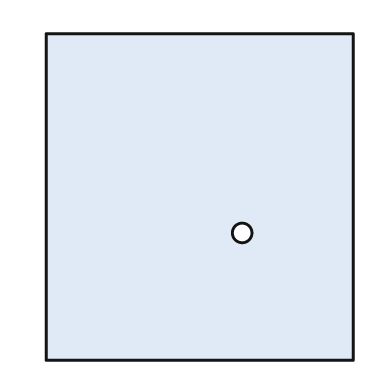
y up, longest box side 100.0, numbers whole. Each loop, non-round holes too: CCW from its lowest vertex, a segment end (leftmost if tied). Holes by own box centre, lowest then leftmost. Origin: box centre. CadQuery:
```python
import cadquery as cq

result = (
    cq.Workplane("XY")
    .moveTo(-47.0, -50.0)
    .lineTo(47.0, -50.0)
    .lineTo(47.0, 50.0)
    .lineTo(-47.0, 50.0)
    .close()
    .moveTo(13.0, -11.0)
    .circle(3.0)
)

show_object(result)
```